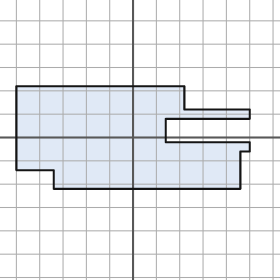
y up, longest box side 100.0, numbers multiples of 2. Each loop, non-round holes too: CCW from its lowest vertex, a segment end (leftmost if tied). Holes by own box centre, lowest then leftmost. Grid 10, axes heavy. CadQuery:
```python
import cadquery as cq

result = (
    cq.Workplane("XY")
    .moveTo(-34.0, -22.0)
    .lineTo(46.0, -22.0)
    .lineTo(46.0, -6.0)
    .lineTo(50.0, -6.0)
    .lineTo(50.0, -2.0)
    .lineTo(14.0, -2.0)
    .lineTo(14.0, 8.0)
    .lineTo(50.0, 8.0)
    .lineTo(50.0, 12.0)
    .lineTo(22.0, 12.0)
    .lineTo(22.0, 22.0)
    .lineTo(-50.0, 22.0)
    .lineTo(-50.0, -14.0)
    .lineTo(-34.0, -14.0)
    .close()
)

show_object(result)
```